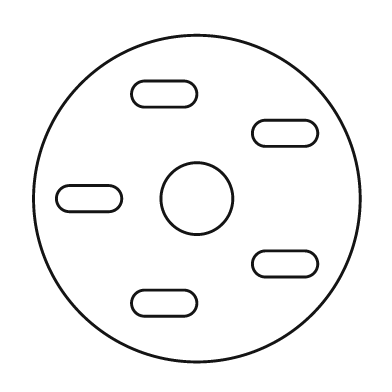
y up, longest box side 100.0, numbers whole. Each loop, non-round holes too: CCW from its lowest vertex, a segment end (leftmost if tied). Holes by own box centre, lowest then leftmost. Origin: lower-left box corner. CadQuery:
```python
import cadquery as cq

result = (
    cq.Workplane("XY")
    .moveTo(50.0, 50.0)
    .circle(50.0)
    .moveTo(34.0, 14.0)
    .lineTo(46.0, 14.0)
    .threePointArc((50.0, 18.0), (46.0, 22.0))
    .lineTo(34.0, 22.0)
    .threePointArc((30.0, 18.0), (34.0, 14.0))
    .close()
    .moveTo(71.0, 26.0)
    .lineTo(83.0, 26.0)
    .threePointArc((87.0, 30.0), (83.0, 34.0))
    .lineTo(71.0, 34.0)
    .threePointArc((67.0, 30.0), (71.0, 26.0))
    .close()
    .moveTo(11.0, 46.0)
    .lineTo(23.0, 46.0)
    .threePointArc((27.0, 50.0), (23.0, 54.0))
    .lineTo(11.0, 54.0)
    .threePointArc((7.0, 50.0), (11.0, 46.0))
    .close()
    .moveTo(50.0, 50.0)
    .circle(11.0)
    .moveTo(71.0, 66.0)
    .lineTo(83.0, 66.0)
    .threePointArc((87.0, 70.0), (83.0, 74.0))
    .lineTo(71.0, 74.0)
    .threePointArc((67.0, 70.0), (71.0, 66.0))
    .close()
    .moveTo(34.0, 78.0)
    .lineTo(46.0, 78.0)
    .threePointArc((50.0, 82.0), (46.0, 86.0))
    .lineTo(34.0, 86.0)
    .threePointArc((30.0, 82.0), (34.0, 78.0))
    .close()
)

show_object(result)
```